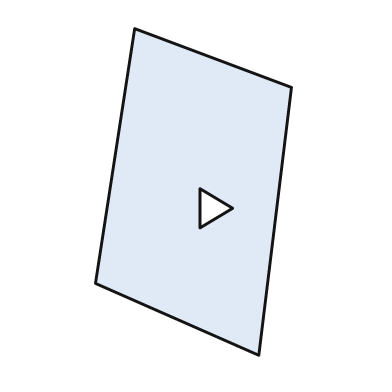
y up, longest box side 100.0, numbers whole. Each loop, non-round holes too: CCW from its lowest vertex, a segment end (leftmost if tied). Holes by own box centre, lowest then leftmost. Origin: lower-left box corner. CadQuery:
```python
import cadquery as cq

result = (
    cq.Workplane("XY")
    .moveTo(50.0, 0.0)
    .lineTo(60.0, 82.0)
    .lineTo(12.0, 100.0)
    .lineTo(0.0, 22.0)
    .close()
    .moveTo(32.0, 39.0)
    .lineTo(42.0, 45.0)
    .lineTo(32.0, 51.0)
    .close()
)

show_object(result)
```